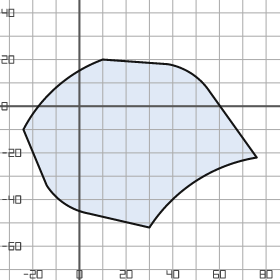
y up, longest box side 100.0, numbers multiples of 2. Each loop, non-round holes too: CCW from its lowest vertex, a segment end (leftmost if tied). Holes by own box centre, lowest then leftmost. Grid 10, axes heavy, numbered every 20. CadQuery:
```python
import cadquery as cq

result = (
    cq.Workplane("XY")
    .moveTo(30.0, -52.0)
    .threePointArc((50.0, -32.0), (76.0, -22.0))
    .lineTo(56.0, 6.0)
    .threePointArc((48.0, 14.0), (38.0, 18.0))
    .lineTo(10.0, 20.0)
    .threePointArc((-10.0, 8.0), (-24.0, -10.0))
    .lineTo(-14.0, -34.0)
    .threePointArc((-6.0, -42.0), (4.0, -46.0))
    .close()
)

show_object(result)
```